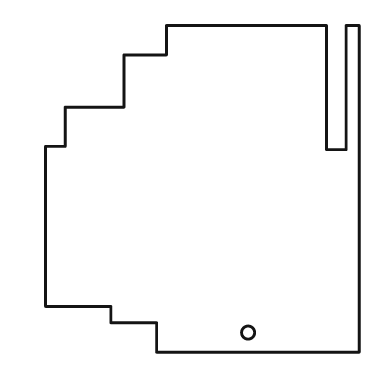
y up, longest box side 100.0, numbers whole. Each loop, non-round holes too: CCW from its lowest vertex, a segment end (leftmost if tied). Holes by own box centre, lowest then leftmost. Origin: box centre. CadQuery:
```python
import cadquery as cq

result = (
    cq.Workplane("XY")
    .moveTo(-14.0, -50.0)
    .lineTo(48.0, -50.0)
    .lineTo(48.0, 50.0)
    .lineTo(44.0, 50.0)
    .lineTo(44.0, 12.0)
    .lineTo(38.0, 12.0)
    .lineTo(38.0, 50.0)
    .lineTo(-11.0, 50.0)
    .lineTo(-11.0, 41.0)
    .lineTo(-24.0, 41.0)
    .lineTo(-24.0, 25.0)
    .lineTo(-42.0, 25.0)
    .lineTo(-42.0, 13.0)
    .lineTo(-48.0, 13.0)
    .lineTo(-48.0, -36.0)
    .lineTo(-28.0, -36.0)
    .lineTo(-28.0, -41.0)
    .lineTo(-14.0, -41.0)
    .close()
    .moveTo(14.0, -44.0)
    .circle(2.0)
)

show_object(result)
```